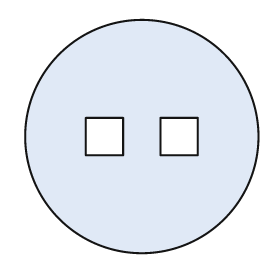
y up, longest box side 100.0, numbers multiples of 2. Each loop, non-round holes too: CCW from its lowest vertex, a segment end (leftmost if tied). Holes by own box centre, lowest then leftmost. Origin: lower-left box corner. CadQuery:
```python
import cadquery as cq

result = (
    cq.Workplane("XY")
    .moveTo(50.0, 50.0)
    .circle(50.0)
    .moveTo(26.0, 42.0)
    .lineTo(42.0, 42.0)
    .lineTo(42.0, 58.0)
    .lineTo(26.0, 58.0)
    .close()
    .moveTo(58.0, 42.0)
    .lineTo(74.0, 42.0)
    .lineTo(74.0, 58.0)
    .lineTo(58.0, 58.0)
    .close()
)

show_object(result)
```